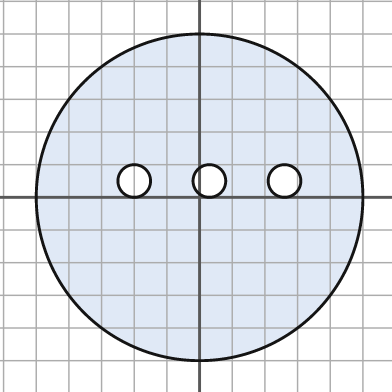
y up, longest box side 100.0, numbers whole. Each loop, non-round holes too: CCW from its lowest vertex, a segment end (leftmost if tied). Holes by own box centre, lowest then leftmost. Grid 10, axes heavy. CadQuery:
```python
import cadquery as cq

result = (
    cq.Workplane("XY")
    .moveTo(0.0, 0.0)
    .circle(50.0)
    .moveTo(-20.0, 5.0)
    .circle(5.0)
    .moveTo(3.0, 5.0)
    .circle(5.0)
    .moveTo(26.0, 5.0)
    .circle(5.0)
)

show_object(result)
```